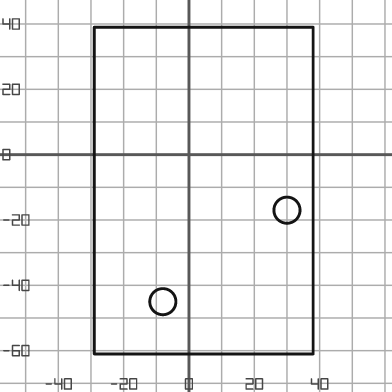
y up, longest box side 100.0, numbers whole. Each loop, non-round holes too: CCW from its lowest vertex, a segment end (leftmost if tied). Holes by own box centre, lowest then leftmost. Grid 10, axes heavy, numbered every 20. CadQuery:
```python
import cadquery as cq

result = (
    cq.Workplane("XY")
    .moveTo(-29.0, -61.0)
    .lineTo(38.0, -61.0)
    .lineTo(38.0, 39.0)
    .lineTo(-29.0, 39.0)
    .close()
    .moveTo(-8.0, -45.0)
    .circle(4.0)
    .moveTo(30.0, -17.0)
    .circle(4.0)
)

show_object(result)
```